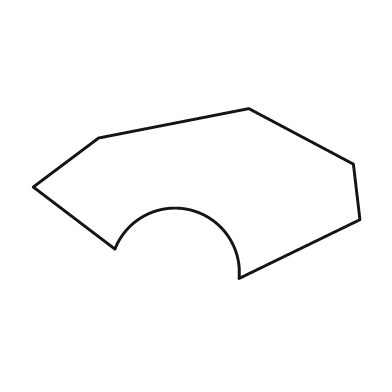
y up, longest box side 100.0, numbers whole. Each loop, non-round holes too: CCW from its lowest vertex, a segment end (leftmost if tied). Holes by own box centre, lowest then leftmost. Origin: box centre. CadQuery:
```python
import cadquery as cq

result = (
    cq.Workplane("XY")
    .moveTo(13.0, -26.0)
    .lineTo(50.0, -8.0)
    .lineTo(48.0, 9.0)
    .lineTo(16.0, 26.0)
    .lineTo(-30.0, 17.0)
    .lineTo(-50.0, 2.0)
    .lineTo(-25.0, -17.0)
    .threePointArc((-2.0, -5.0), (13.0, -26.0))
    .close()
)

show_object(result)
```